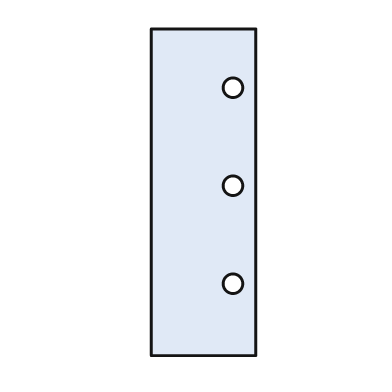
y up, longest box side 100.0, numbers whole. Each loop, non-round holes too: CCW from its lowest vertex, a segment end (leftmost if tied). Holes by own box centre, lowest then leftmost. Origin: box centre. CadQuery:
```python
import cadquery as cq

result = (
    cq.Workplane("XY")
    .moveTo(-16.0, -50.0)
    .lineTo(16.0, -50.0)
    .lineTo(16.0, 50.0)
    .lineTo(-16.0, 50.0)
    .close()
    .moveTo(9.0, -28.0)
    .circle(3.0)
    .moveTo(9.0, 2.0)
    .circle(3.0)
    .moveTo(9.0, 32.0)
    .circle(3.0)
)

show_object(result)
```